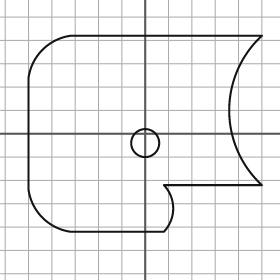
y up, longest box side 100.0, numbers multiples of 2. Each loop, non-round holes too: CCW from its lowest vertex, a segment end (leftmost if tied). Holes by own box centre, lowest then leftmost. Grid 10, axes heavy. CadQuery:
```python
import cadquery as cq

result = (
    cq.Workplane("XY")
    .moveTo(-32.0, -42.0)
    .lineTo(8.0, -42.0)
    .threePointArc((12.0, -32.0), (8.0, -22.0))
    .lineTo(50.0, -22.0)
    .threePointArc((36.0, 10.0), (50.0, 42.0))
    .lineTo(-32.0, 42.0)
    .threePointArc((-44.0, 36.0), (-50.0, 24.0))
    .lineTo(-50.0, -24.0)
    .threePointArc((-44.0, -36.0), (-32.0, -42.0))
    .close()
    .moveTo(0.0, -4.0)
    .circle(6.0)
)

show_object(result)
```